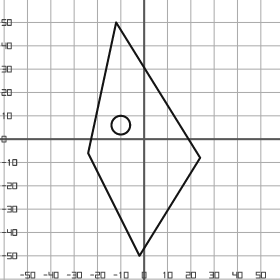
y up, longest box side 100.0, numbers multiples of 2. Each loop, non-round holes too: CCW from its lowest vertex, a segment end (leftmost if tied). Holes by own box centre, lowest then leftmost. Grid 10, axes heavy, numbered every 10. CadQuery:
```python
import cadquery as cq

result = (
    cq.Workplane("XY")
    .moveTo(-2.0, -50.0)
    .lineTo(24.0, -8.0)
    .lineTo(-12.0, 50.0)
    .lineTo(-24.0, -6.0)
    .close()
    .moveTo(-10.0, 6.0)
    .circle(4.0)
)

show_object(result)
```